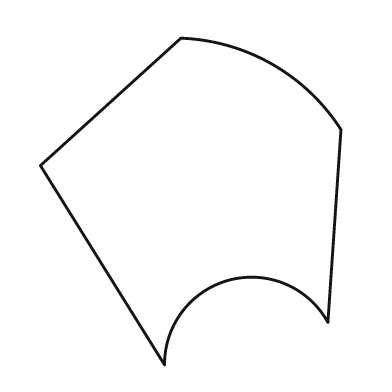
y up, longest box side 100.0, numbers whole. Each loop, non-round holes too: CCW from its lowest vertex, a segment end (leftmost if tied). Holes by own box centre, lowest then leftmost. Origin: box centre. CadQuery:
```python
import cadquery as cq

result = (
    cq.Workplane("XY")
    .moveTo(-8.0, -50.0)
    .threePointArc((12.0, -24.0), (42.0, -37.0))
    .lineTo(46.0, 22.0)
    .threePointArc((25.0, 42.0), (-3.0, 50.0))
    .lineTo(-46.0, 11.0)
    .close()
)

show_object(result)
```